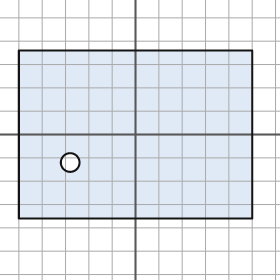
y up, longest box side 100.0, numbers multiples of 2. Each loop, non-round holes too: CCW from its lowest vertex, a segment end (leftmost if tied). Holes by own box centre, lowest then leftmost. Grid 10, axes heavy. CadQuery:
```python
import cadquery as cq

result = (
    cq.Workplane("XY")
    .moveTo(-50.0, -36.0)
    .lineTo(50.0, -36.0)
    .lineTo(50.0, 36.0)
    .lineTo(-50.0, 36.0)
    .close()
    .moveTo(-28.0, -12.0)
    .circle(4.0)
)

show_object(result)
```